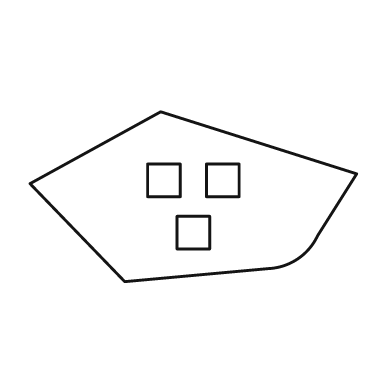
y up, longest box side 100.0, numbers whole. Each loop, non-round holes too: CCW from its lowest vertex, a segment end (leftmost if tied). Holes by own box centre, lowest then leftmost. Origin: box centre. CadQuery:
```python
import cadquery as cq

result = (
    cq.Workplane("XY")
    .moveTo(-21.0, -26.0)
    .lineTo(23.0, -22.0)
    .threePointArc((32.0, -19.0), (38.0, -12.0))
    .lineTo(50.0, 7.0)
    .lineTo(-10.0, 26.0)
    .lineTo(-50.0, 4.0)
    .close()
    .moveTo(-5.0, -16.0)
    .lineTo(5.0, -16.0)
    .lineTo(5.0, -6.0)
    .lineTo(-5.0, -6.0)
    .close()
    .moveTo(-14.0, 0.0)
    .lineTo(-4.0, 0.0)
    .lineTo(-4.0, 10.0)
    .lineTo(-14.0, 10.0)
    .close()
    .moveTo(4.0, 0.0)
    .lineTo(14.0, 0.0)
    .lineTo(14.0, 10.0)
    .lineTo(4.0, 10.0)
    .close()
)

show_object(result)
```